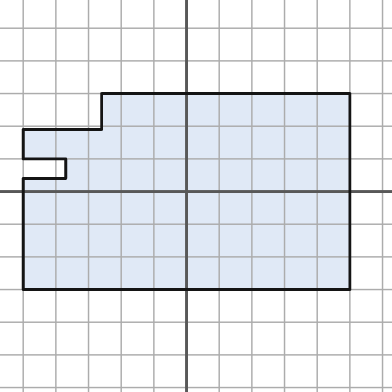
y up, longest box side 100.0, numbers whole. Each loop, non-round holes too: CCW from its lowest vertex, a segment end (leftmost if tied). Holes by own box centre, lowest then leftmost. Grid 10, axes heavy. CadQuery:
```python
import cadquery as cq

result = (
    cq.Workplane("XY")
    .moveTo(-50.0, -30.0)
    .lineTo(50.0, -30.0)
    .lineTo(50.0, 30.0)
    .lineTo(-26.0, 30.0)
    .lineTo(-26.0, 19.0)
    .lineTo(-50.0, 19.0)
    .lineTo(-50.0, 10.0)
    .lineTo(-37.0, 10.0)
    .lineTo(-37.0, 4.0)
    .lineTo(-50.0, 4.0)
    .close()
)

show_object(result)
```